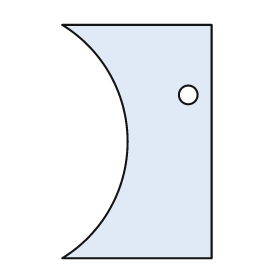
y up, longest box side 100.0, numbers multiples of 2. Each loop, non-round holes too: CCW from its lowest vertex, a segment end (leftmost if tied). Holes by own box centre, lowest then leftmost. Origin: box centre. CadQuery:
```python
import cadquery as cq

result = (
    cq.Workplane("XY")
    .moveTo(-32.0, -50.0)
    .lineTo(32.0, -50.0)
    .lineTo(32.0, 50.0)
    .lineTo(-32.0, 50.0)
    .threePointArc((-4.0, 0.0), (-32.0, -50.0))
    .close()
    .moveTo(22.0, 20.0)
    .circle(4.0)
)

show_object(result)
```